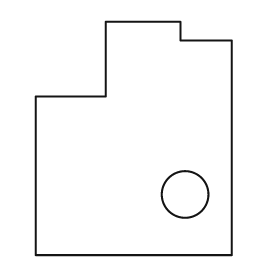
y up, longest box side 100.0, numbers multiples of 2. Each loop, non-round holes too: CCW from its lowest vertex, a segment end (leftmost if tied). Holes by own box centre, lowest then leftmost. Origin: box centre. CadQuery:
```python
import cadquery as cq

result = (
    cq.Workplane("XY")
    .moveTo(-42.0, -50.0)
    .lineTo(42.0, -50.0)
    .lineTo(42.0, 42.0)
    .lineTo(20.0, 42.0)
    .lineTo(20.0, 50.0)
    .lineTo(-12.0, 50.0)
    .lineTo(-12.0, 18.0)
    .lineTo(-42.0, 18.0)
    .close()
    .moveTo(22.0, -24.0)
    .circle(10.0)
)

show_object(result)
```